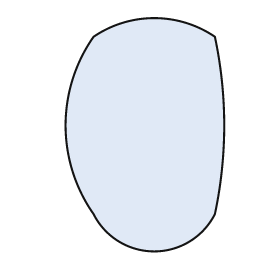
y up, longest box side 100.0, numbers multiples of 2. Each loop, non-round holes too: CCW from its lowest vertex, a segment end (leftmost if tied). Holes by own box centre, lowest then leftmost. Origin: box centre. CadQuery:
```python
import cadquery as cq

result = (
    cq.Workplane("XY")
    .moveTo(-22.0, -34.0)
    .threePointArc((4.0, -50.0), (30.0, -34.0))
    .threePointArc((34.0, 4.0), (30.0, 42.0))
    .threePointArc((4.0, 50.0), (-22.0, 42.0))
    .threePointArc((-34.0, 4.0), (-22.0, -34.0))
    .close()
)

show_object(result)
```